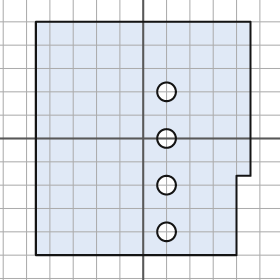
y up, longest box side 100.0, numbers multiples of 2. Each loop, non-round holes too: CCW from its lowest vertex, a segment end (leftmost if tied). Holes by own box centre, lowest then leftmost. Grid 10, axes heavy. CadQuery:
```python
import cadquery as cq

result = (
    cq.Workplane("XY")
    .moveTo(-46.0, -50.0)
    .lineTo(40.0, -50.0)
    .lineTo(40.0, -16.0)
    .lineTo(46.0, -16.0)
    .lineTo(46.0, 50.0)
    .lineTo(-46.0, 50.0)
    .close()
    .moveTo(10.0, -40.0)
    .circle(4.0)
    .moveTo(10.0, -20.0)
    .circle(4.0)
    .moveTo(10.0, 0.0)
    .circle(4.0)
    .moveTo(10.0, 20.0)
    .circle(4.0)
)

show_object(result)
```